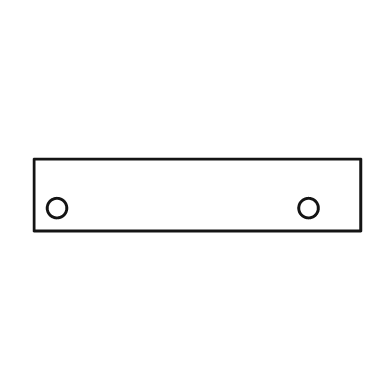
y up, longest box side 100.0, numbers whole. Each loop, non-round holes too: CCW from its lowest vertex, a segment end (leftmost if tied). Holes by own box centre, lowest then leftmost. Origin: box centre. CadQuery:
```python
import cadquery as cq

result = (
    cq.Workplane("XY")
    .moveTo(-50.0, -11.0)
    .lineTo(50.0, -11.0)
    .lineTo(50.0, 11.0)
    .lineTo(-50.0, 11.0)
    .close()
    .moveTo(-43.0, -4.0)
    .circle(3.0)
    .moveTo(34.0, -4.0)
    .circle(3.0)
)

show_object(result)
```